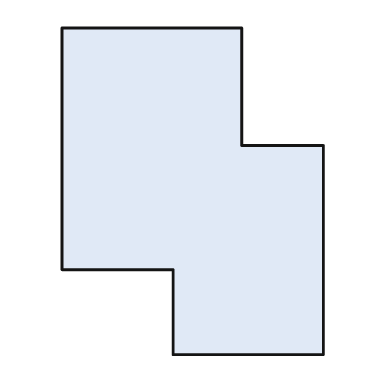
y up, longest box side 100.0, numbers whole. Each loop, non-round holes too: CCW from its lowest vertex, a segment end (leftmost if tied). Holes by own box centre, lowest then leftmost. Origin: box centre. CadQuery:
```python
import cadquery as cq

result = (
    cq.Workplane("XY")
    .moveTo(-6.0, -50.0)
    .lineTo(40.0, -50.0)
    .lineTo(40.0, 14.0)
    .lineTo(15.0, 14.0)
    .lineTo(15.0, 50.0)
    .lineTo(-40.0, 50.0)
    .lineTo(-40.0, -24.0)
    .lineTo(-6.0, -24.0)
    .close()
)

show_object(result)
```